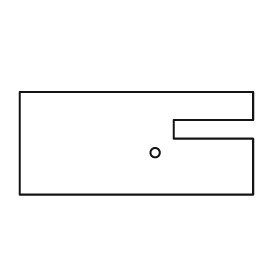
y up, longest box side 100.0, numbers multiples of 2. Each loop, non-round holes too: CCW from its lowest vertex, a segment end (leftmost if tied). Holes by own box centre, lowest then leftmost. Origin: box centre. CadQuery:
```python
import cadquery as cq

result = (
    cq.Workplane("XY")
    .moveTo(-50.0, -22.0)
    .lineTo(50.0, -22.0)
    .lineTo(50.0, 2.0)
    .lineTo(16.0, 2.0)
    .lineTo(16.0, 10.0)
    .lineTo(50.0, 10.0)
    .lineTo(50.0, 22.0)
    .lineTo(-50.0, 22.0)
    .close()
    .moveTo(8.0, -4.0)
    .circle(2.0)
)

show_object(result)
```